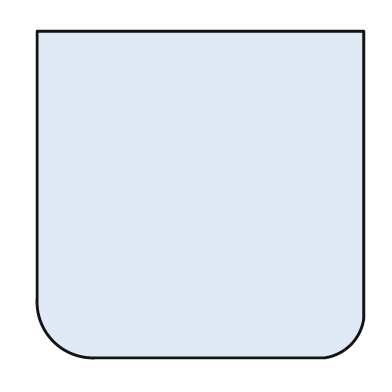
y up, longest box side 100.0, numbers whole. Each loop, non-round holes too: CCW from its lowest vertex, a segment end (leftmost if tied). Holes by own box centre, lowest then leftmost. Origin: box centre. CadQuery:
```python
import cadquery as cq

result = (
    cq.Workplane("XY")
    .moveTo(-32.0, -50.0)
    .lineTo(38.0, -50.0)
    .threePointArc((46.0, -46.0), (50.0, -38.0))
    .lineTo(50.0, 50.0)
    .lineTo(-50.0, 50.0)
    .lineTo(-50.0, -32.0)
    .threePointArc((-45.0, -45.0), (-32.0, -50.0))
    .close()
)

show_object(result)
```